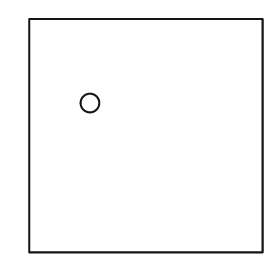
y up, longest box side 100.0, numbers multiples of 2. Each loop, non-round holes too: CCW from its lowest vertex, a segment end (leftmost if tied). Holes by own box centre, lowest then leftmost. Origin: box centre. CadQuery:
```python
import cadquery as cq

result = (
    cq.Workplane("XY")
    .moveTo(-50.0, -50.0)
    .lineTo(50.0, -50.0)
    .lineTo(50.0, 50.0)
    .lineTo(-50.0, 50.0)
    .close()
    .moveTo(-24.0, 14.0)
    .circle(4.0)
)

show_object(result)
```